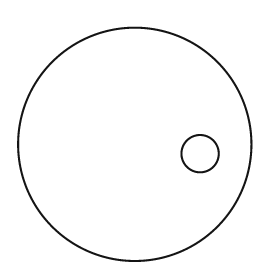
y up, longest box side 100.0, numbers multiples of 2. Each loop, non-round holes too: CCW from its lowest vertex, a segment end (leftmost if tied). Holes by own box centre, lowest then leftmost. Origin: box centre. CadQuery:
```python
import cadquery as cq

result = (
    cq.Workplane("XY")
    .moveTo(0.0, 0.0)
    .circle(50.0)
    .moveTo(28.0, -4.0)
    .circle(8.0)
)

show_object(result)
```